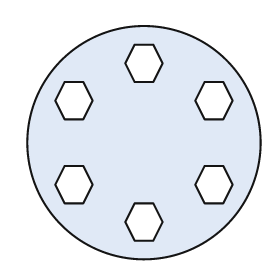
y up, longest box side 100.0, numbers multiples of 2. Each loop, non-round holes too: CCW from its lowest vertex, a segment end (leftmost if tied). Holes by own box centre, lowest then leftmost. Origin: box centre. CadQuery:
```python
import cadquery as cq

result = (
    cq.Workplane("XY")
    .moveTo(0.0, 0.0)
    .circle(50.0)
    .moveTo(-4.0, -42.0)
    .lineTo(4.0, -42.0)
    .lineTo(8.0, -34.0)
    .lineTo(4.0, -26.0)
    .lineTo(-4.0, -26.0)
    .lineTo(-8.0, -34.0)
    .close()
    .moveTo(-34.0, -26.0)
    .lineTo(-26.0, -26.0)
    .lineTo(-22.0, -18.0)
    .lineTo(-26.0, -10.0)
    .lineTo(-34.0, -10.0)
    .lineTo(-38.0, -18.0)
    .close()
    .moveTo(26.0, -26.0)
    .lineTo(34.0, -26.0)
    .lineTo(38.0, -18.0)
    .lineTo(34.0, -10.0)
    .lineTo(26.0, -10.0)
    .lineTo(22.0, -18.0)
    .close()
    .moveTo(-34.0, 10.0)
    .lineTo(-26.0, 10.0)
    .lineTo(-22.0, 18.0)
    .lineTo(-26.0, 26.0)
    .lineTo(-34.0, 26.0)
    .lineTo(-38.0, 18.0)
    .close()
    .moveTo(26.0, 10.0)
    .lineTo(34.0, 10.0)
    .lineTo(38.0, 18.0)
    .lineTo(34.0, 26.0)
    .lineTo(26.0, 26.0)
    .lineTo(22.0, 18.0)
    .close()
    .moveTo(-4.0, 26.0)
    .lineTo(4.0, 26.0)
    .lineTo(8.0, 34.0)
    .lineTo(4.0, 42.0)
    .lineTo(-4.0, 42.0)
    .lineTo(-8.0, 34.0)
    .close()
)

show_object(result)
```